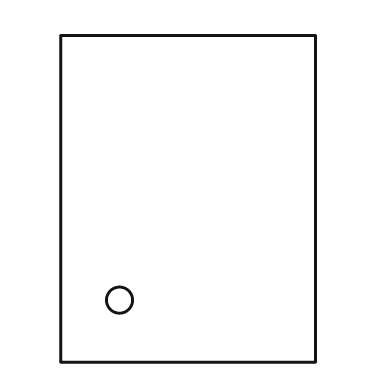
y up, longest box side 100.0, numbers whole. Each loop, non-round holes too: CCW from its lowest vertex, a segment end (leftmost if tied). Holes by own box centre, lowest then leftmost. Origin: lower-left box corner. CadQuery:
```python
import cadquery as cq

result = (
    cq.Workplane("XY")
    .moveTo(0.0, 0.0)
    .lineTo(78.0, 0.0)
    .lineTo(78.0, 100.0)
    .lineTo(0.0, 100.0)
    .close()
    .moveTo(18.0, 19.0)
    .circle(4.0)
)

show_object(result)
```